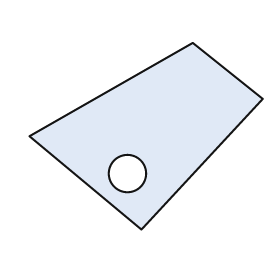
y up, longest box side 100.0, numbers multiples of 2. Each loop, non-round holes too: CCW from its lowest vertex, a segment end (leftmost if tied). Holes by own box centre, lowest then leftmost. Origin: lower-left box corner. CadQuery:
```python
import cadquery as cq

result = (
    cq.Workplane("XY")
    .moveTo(48.0, 0.0)
    .lineTo(100.0, 56.0)
    .lineTo(70.0, 80.0)
    .lineTo(0.0, 40.0)
    .close()
    .moveTo(42.0, 24.0)
    .circle(8.0)
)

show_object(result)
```